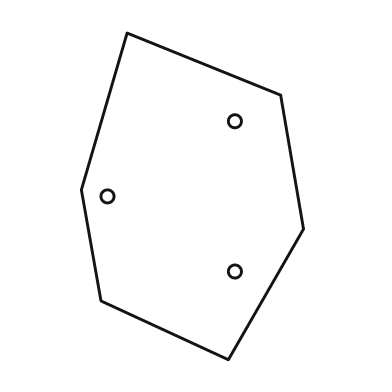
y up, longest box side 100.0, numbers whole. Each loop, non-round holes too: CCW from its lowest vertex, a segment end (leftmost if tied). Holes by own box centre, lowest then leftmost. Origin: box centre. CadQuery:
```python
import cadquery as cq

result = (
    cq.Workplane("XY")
    .moveTo(11.0, -50.0)
    .lineTo(34.0, -10.0)
    .lineTo(27.0, 31.0)
    .lineTo(-20.0, 50.0)
    .lineTo(-34.0, 2.0)
    .lineTo(-28.0, -32.0)
    .close()
    .moveTo(13.0, -23.0)
    .circle(2.0)
    .moveTo(-26.0, 0.0)
    .circle(2.0)
    .moveTo(13.0, 23.0)
    .circle(2.0)
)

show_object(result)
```